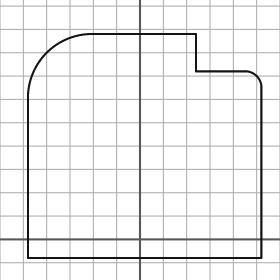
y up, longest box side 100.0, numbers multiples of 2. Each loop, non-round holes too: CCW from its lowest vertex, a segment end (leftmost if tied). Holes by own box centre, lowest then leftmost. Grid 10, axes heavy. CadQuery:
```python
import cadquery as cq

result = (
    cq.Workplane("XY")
    .moveTo(-48.0, -8.0)
    .lineTo(52.0, -8.0)
    .lineTo(52.0, 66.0)
    .threePointArc((50.0, 70.0), (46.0, 72.0))
    .lineTo(24.0, 72.0)
    .lineTo(24.0, 88.0)
    .lineTo(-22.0, 88.0)
    .threePointArc((-40.0, 80.0), (-48.0, 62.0))
    .close()
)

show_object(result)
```